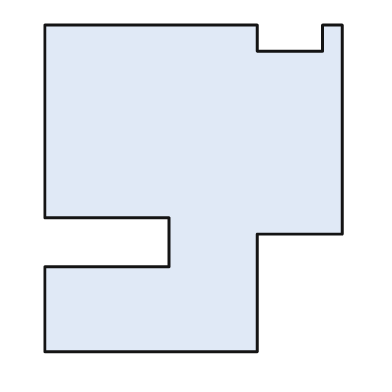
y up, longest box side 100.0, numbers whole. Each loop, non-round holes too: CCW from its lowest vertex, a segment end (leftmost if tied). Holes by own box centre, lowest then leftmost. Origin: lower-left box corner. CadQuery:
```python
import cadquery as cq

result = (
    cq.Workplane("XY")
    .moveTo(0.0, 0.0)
    .lineTo(65.0, 0.0)
    .lineTo(65.0, 36.0)
    .lineTo(91.0, 36.0)
    .lineTo(91.0, 100.0)
    .lineTo(85.0, 100.0)
    .lineTo(85.0, 92.0)
    .lineTo(65.0, 92.0)
    .lineTo(65.0, 100.0)
    .lineTo(0.0, 100.0)
    .lineTo(0.0, 41.0)
    .lineTo(38.0, 41.0)
    .lineTo(38.0, 26.0)
    .lineTo(0.0, 26.0)
    .close()
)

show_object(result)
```